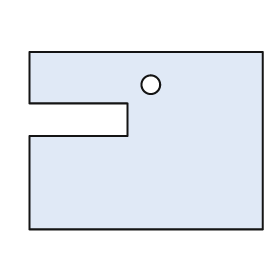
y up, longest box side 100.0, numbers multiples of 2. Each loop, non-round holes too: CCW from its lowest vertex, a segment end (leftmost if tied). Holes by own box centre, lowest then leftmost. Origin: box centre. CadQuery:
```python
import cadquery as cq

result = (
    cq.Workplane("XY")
    .moveTo(-50.0, -38.0)
    .lineTo(50.0, -38.0)
    .lineTo(50.0, 38.0)
    .lineTo(-50.0, 38.0)
    .lineTo(-50.0, 16.0)
    .lineTo(-8.0, 16.0)
    .lineTo(-8.0, 2.0)
    .lineTo(-50.0, 2.0)
    .close()
    .moveTo(2.0, 24.0)
    .circle(4.0)
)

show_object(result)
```